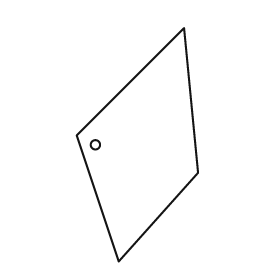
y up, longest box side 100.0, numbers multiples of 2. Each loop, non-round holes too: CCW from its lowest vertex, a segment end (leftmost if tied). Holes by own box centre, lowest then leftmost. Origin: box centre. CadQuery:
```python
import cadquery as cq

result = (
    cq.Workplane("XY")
    .moveTo(-8.0, -50.0)
    .lineTo(26.0, -12.0)
    .lineTo(20.0, 50.0)
    .lineTo(-26.0, 4.0)
    .close()
    .moveTo(-18.0, 0.0)
    .circle(2.0)
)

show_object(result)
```